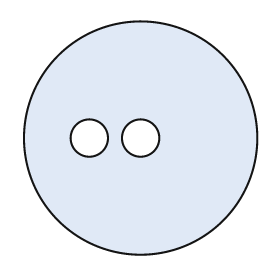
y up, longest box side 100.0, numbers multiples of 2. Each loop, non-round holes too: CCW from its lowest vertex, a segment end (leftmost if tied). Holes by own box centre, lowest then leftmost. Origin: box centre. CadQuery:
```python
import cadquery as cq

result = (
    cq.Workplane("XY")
    .moveTo(0.0, 0.0)
    .circle(50.0)
    .moveTo(-22.0, 0.0)
    .circle(8.0)
    .moveTo(0.0, 0.0)
    .circle(8.0)
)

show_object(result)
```